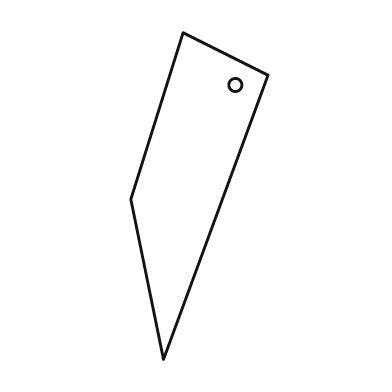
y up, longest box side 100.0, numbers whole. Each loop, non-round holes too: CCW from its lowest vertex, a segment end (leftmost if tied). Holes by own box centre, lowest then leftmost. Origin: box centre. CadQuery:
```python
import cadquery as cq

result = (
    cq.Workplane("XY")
    .moveTo(-11.0, -50.0)
    .lineTo(21.0, 37.0)
    .lineTo(-5.0, 50.0)
    .lineTo(-21.0, -1.0)
    .close()
    .moveTo(11.0, 34.0)
    .circle(2.0)
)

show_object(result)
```